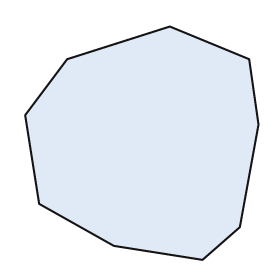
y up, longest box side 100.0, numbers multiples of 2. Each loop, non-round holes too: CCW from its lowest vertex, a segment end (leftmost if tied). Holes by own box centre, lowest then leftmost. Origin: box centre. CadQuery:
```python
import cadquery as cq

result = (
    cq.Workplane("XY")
    .moveTo(26.0, -50.0)
    .lineTo(42.0, -36.0)
    .lineTo(50.0, 8.0)
    .lineTo(46.0, 36.0)
    .lineTo(12.0, 50.0)
    .lineTo(-32.0, 36.0)
    .lineTo(-50.0, 12.0)
    .lineTo(-44.0, -26.0)
    .lineTo(-12.0, -44.0)
    .close()
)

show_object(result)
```